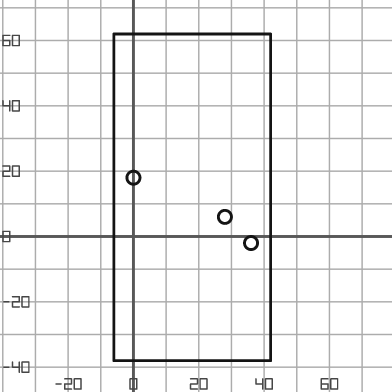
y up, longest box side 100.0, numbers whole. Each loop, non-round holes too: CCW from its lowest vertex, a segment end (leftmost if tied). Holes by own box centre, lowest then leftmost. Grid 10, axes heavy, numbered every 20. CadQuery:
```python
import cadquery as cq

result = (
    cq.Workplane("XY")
    .moveTo(-6.0, -38.0)
    .lineTo(42.0, -38.0)
    .lineTo(42.0, 62.0)
    .lineTo(-6.0, 62.0)
    .close()
    .moveTo(36.0, -2.0)
    .circle(2.0)
    .moveTo(28.0, 6.0)
    .circle(2.0)
    .moveTo(0.0, 18.0)
    .circle(2.0)
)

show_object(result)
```